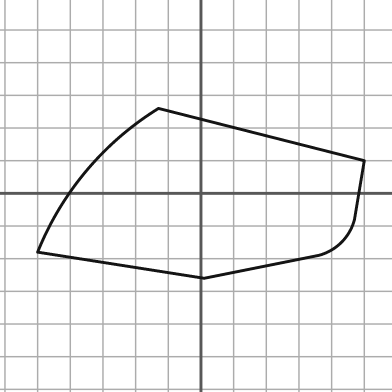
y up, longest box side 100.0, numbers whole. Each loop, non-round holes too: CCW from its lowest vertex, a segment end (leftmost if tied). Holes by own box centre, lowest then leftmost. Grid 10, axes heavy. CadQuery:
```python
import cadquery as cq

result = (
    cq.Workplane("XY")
    .moveTo(1.0, -26.0)
    .lineTo(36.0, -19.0)
    .threePointArc((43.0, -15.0), (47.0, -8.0))
    .lineTo(50.0, 10.0)
    .lineTo(-13.0, 26.0)
    .threePointArc((-35.0, 7.0), (-50.0, -18.0))
    .close()
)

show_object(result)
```